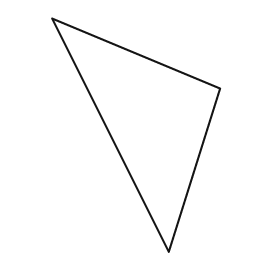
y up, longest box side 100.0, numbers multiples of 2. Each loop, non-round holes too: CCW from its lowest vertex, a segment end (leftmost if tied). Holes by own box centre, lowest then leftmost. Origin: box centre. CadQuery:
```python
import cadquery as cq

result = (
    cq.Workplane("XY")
    .moveTo(14.0, -50.0)
    .lineTo(36.0, 20.0)
    .lineTo(-36.0, 50.0)
    .close()
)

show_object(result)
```